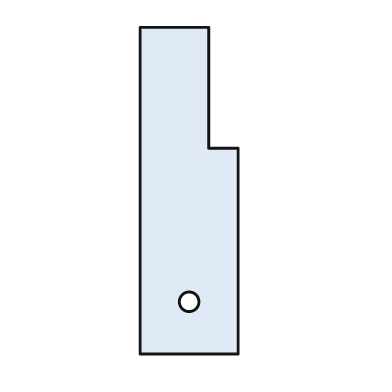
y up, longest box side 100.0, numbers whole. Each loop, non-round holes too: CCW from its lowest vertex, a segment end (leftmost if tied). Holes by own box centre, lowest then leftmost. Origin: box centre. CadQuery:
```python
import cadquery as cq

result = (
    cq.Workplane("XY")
    .moveTo(-15.0, -50.0)
    .lineTo(15.0, -50.0)
    .lineTo(15.0, 13.0)
    .lineTo(6.0, 13.0)
    .lineTo(6.0, 50.0)
    .lineTo(-15.0, 50.0)
    .close()
    .moveTo(0.0, -34.0)
    .circle(3.0)
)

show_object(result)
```